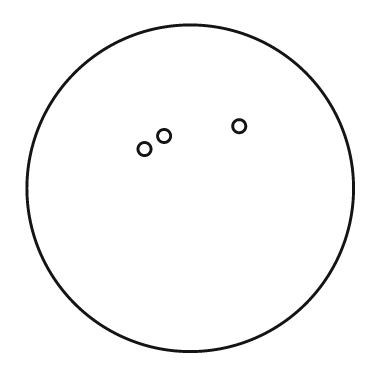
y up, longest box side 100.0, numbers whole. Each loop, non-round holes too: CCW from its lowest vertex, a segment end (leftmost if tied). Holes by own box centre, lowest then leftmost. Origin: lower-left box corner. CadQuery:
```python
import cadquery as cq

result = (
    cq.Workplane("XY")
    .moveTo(50.0, 50.0)
    .circle(50.0)
    .moveTo(36.0, 62.0)
    .circle(2.0)
    .moveTo(42.0, 66.0)
    .circle(2.0)
    .moveTo(65.0, 69.0)
    .circle(2.0)
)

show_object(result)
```